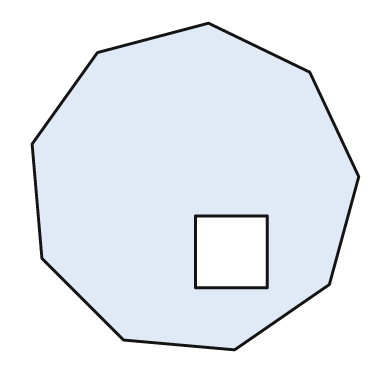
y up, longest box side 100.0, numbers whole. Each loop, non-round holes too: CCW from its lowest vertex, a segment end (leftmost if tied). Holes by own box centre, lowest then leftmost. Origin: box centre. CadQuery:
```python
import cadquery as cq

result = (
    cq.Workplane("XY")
    .moveTo(12.0, -50.0)
    .lineTo(41.0, -30.0)
    .lineTo(50.0, 3.0)
    .lineTo(35.0, 35.0)
    .lineTo(4.0, 50.0)
    .lineTo(-30.0, 41.0)
    .lineTo(-50.0, 13.0)
    .lineTo(-47.0, -22.0)
    .lineTo(-22.0, -47.0)
    .close()
    .moveTo(0.0, -31.0)
    .lineTo(22.0, -31.0)
    .lineTo(22.0, -9.0)
    .lineTo(0.0, -9.0)
    .close()
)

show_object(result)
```